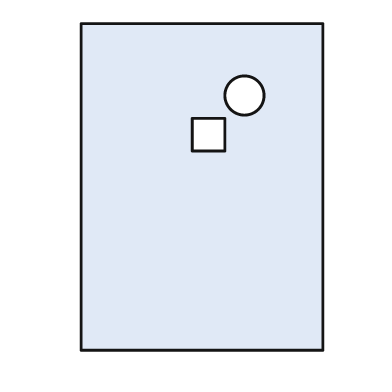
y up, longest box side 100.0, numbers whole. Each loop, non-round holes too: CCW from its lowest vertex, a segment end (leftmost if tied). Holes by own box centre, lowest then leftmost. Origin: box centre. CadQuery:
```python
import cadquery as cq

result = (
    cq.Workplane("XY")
    .moveTo(-37.0, -50.0)
    .lineTo(37.0, -50.0)
    .lineTo(37.0, 50.0)
    .lineTo(-37.0, 50.0)
    .close()
    .moveTo(-3.0, 11.0)
    .lineTo(7.0, 11.0)
    .lineTo(7.0, 21.0)
    .lineTo(-3.0, 21.0)
    .close()
    .moveTo(13.0, 28.0)
    .circle(6.0)
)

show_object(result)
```